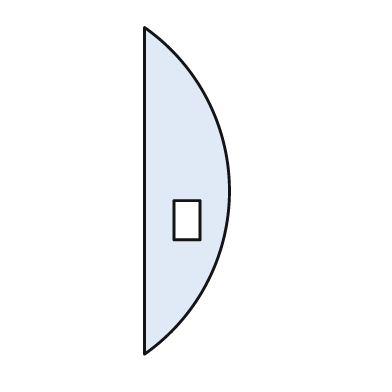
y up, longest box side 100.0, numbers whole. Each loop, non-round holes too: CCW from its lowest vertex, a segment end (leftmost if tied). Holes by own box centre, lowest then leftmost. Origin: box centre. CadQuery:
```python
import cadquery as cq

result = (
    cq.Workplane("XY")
    .moveTo(-13.0, -50.0)
    .threePointArc((13.0, 0.0), (-13.0, 50.0))
    .close()
    .moveTo(-4.0, -15.0)
    .lineTo(4.0, -15.0)
    .lineTo(4.0, -3.0)
    .lineTo(-4.0, -3.0)
    .close()
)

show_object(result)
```